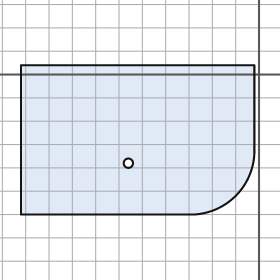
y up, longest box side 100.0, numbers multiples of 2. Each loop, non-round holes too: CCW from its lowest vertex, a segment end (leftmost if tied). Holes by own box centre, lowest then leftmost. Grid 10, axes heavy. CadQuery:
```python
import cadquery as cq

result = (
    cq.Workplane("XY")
    .moveTo(-102.0, -60.0)
    .lineTo(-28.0, -60.0)
    .threePointArc((-10.0, -52.0), (-2.0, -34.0))
    .lineTo(-2.0, 4.0)
    .lineTo(-102.0, 4.0)
    .close()
    .moveTo(-56.0, -38.0)
    .circle(2.0)
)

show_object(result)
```